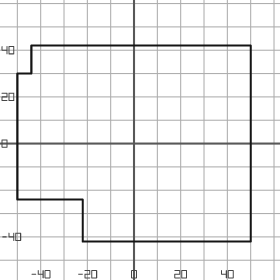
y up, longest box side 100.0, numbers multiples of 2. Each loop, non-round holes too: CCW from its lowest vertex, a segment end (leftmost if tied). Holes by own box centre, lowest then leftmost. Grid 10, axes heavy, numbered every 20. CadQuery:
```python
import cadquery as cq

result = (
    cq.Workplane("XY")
    .moveTo(-22.0, -42.0)
    .lineTo(50.0, -42.0)
    .lineTo(50.0, 42.0)
    .lineTo(-44.0, 42.0)
    .lineTo(-44.0, 30.0)
    .lineTo(-50.0, 30.0)
    .lineTo(-50.0, -24.0)
    .lineTo(-22.0, -24.0)
    .close()
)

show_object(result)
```